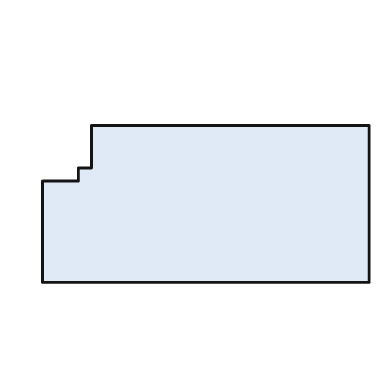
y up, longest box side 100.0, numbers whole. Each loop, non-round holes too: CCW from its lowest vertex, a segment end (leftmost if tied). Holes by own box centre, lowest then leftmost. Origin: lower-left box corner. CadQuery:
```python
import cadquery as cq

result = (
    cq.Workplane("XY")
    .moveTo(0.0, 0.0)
    .lineTo(100.0, 0.0)
    .lineTo(100.0, 48.0)
    .lineTo(15.0, 48.0)
    .lineTo(15.0, 35.0)
    .lineTo(11.0, 35.0)
    .lineTo(11.0, 31.0)
    .lineTo(0.0, 31.0)
    .close()
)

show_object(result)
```